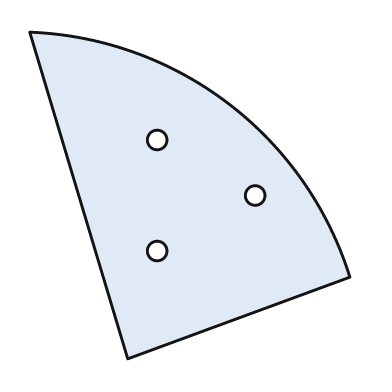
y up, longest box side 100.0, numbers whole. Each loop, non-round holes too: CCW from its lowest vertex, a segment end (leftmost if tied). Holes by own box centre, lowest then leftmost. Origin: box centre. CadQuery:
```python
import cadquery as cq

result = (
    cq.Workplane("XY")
    .moveTo(-19.0, -50.0)
    .lineTo(49.0, -25.0)
    .threePointArc((12.0, 28.0), (-49.0, 50.0))
    .close()
    .moveTo(-10.0, -17.0)
    .circle(3.0)
    .moveTo(20.0, 0.0)
    .circle(3.0)
    .moveTo(-10.0, 17.0)
    .circle(3.0)
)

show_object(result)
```